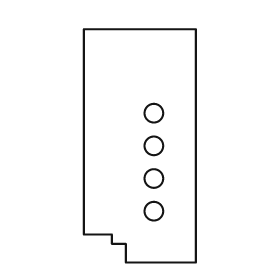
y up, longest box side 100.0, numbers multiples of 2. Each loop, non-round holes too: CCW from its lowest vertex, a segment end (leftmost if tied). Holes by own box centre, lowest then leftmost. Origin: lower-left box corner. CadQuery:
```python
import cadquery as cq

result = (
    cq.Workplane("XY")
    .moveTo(18.0, 0.0)
    .lineTo(48.0, 0.0)
    .lineTo(48.0, 100.0)
    .lineTo(0.0, 100.0)
    .lineTo(0.0, 12.0)
    .lineTo(12.0, 12.0)
    .lineTo(12.0, 8.0)
    .lineTo(18.0, 8.0)
    .close()
    .moveTo(30.0, 22.0)
    .circle(4.0)
    .moveTo(30.0, 36.0)
    .circle(4.0)
    .moveTo(30.0, 50.0)
    .circle(4.0)
    .moveTo(30.0, 64.0)
    .circle(4.0)
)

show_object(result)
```